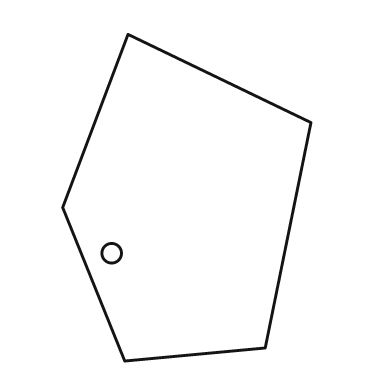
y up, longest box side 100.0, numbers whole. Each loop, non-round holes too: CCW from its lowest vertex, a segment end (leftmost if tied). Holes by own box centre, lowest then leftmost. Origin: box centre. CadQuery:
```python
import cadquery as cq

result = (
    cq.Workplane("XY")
    .moveTo(-19.0, -50.0)
    .lineTo(24.0, -46.0)
    .lineTo(38.0, 23.0)
    .lineTo(-18.0, 50.0)
    .lineTo(-38.0, -3.0)
    .close()
    .moveTo(-23.0, -17.0)
    .circle(3.0)
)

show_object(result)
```